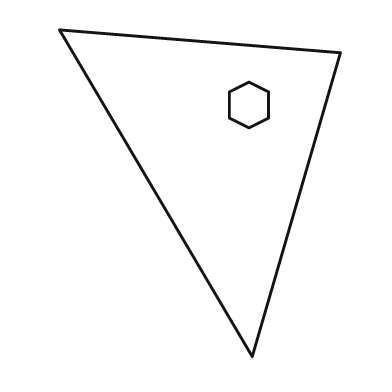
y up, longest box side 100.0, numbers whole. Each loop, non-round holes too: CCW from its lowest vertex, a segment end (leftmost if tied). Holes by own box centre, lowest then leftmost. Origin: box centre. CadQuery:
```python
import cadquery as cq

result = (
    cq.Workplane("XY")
    .moveTo(16.0, -50.0)
    .lineTo(43.0, 43.0)
    .lineTo(-43.0, 50.0)
    .close()
    .moveTo(15.0, 20.0)
    .lineTo(21.0, 23.0)
    .lineTo(21.0, 31.0)
    .lineTo(15.0, 34.0)
    .lineTo(9.0, 31.0)
    .lineTo(9.0, 23.0)
    .close()
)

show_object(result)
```